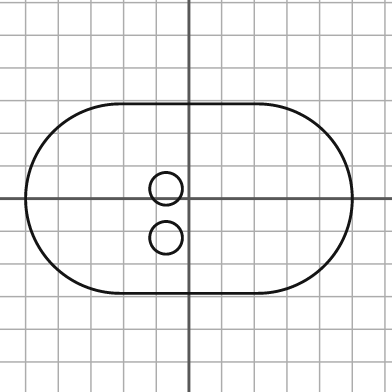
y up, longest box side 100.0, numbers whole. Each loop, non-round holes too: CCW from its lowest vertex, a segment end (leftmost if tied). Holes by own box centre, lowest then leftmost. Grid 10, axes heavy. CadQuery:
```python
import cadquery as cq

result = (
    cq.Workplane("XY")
    .moveTo(-21.0, -29.0)
    .lineTo(21.0, -29.0)
    .threePointArc((50.0, 0.0), (21.0, 29.0))
    .lineTo(-21.0, 29.0)
    .threePointArc((-50.0, 0.0), (-21.0, -29.0))
    .close()
    .moveTo(-7.0, -12.0)
    .circle(5.0)
    .moveTo(-7.0, 3.0)
    .circle(5.0)
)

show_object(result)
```